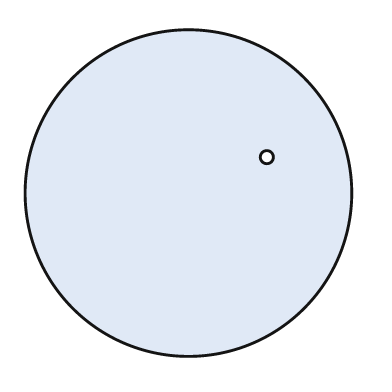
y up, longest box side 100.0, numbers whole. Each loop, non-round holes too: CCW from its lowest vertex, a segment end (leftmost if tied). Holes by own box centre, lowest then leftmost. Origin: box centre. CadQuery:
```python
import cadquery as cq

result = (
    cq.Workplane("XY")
    .moveTo(0.0, 0.0)
    .circle(50.0)
    .moveTo(24.0, 11.0)
    .circle(2.0)
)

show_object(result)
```